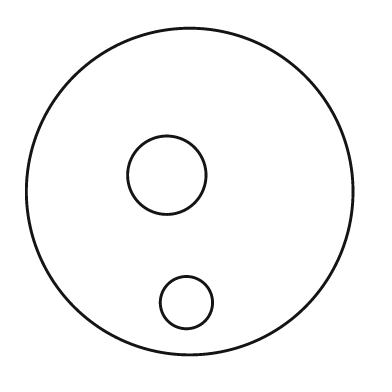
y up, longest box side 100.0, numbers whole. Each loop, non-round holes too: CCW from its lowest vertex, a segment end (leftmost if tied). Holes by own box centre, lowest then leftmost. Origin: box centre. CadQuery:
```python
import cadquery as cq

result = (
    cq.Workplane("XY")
    .moveTo(0.0, 0.0)
    .circle(50.0)
    .moveTo(-1.0, -34.0)
    .circle(8.0)
    .moveTo(-7.0, 5.0)
    .circle(12.0)
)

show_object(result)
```